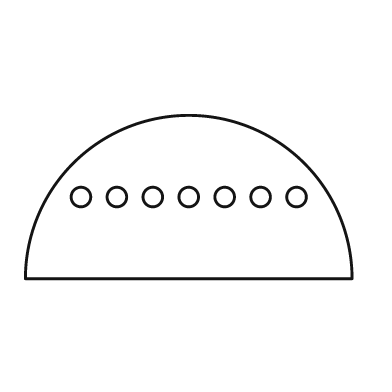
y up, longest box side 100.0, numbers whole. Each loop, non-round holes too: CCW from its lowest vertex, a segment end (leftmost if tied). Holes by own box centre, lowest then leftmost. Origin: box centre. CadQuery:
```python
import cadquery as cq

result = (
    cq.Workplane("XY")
    .moveTo(-50.0, -25.0)
    .lineTo(50.0, -25.0)
    .threePointArc((0.0, 25.0), (-50.0, -25.0))
    .close()
    .moveTo(-33.0, 0.0)
    .circle(3.0)
    .moveTo(-22.0, 0.0)
    .circle(3.0)
    .moveTo(-11.0, 0.0)
    .circle(3.0)
    .moveTo(0.0, 0.0)
    .circle(3.0)
    .moveTo(11.0, 0.0)
    .circle(3.0)
    .moveTo(22.0, 0.0)
    .circle(3.0)
    .moveTo(33.0, 0.0)
    .circle(3.0)
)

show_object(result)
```